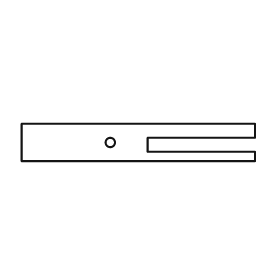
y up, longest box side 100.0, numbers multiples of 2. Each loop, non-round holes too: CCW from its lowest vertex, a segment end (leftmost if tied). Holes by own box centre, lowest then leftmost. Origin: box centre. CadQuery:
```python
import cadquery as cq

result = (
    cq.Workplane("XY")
    .moveTo(-50.0, -8.0)
    .lineTo(50.0, -8.0)
    .lineTo(50.0, -4.0)
    .lineTo(4.0, -4.0)
    .lineTo(4.0, 2.0)
    .lineTo(50.0, 2.0)
    .lineTo(50.0, 8.0)
    .lineTo(-50.0, 8.0)
    .close()
    .moveTo(-12.0, 0.0)
    .circle(2.0)
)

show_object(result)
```